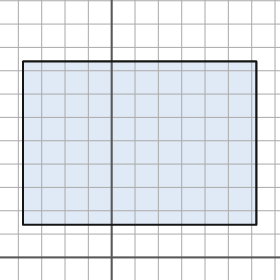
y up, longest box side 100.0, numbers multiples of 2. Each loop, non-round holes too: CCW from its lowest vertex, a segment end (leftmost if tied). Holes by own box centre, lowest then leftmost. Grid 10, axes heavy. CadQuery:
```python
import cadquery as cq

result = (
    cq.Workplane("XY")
    .moveTo(-38.0, 14.0)
    .lineTo(62.0, 14.0)
    .lineTo(62.0, 84.0)
    .lineTo(-38.0, 84.0)
    .close()
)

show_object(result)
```